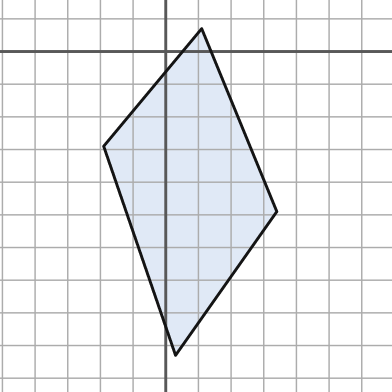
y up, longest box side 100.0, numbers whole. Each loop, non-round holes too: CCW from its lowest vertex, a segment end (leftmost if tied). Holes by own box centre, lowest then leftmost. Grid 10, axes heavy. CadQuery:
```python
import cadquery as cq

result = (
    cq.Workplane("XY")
    .moveTo(3.0, -93.0)
    .lineTo(34.0, -49.0)
    .lineTo(11.0, 7.0)
    .lineTo(-19.0, -29.0)
    .close()
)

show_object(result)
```